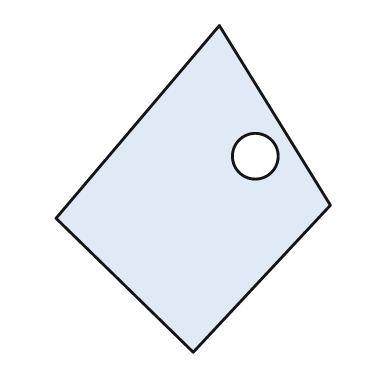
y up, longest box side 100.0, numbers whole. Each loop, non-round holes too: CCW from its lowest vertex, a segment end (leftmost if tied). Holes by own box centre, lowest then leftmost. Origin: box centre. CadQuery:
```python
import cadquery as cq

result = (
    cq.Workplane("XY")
    .moveTo(0.0, -50.0)
    .lineTo(42.0, -5.0)
    .lineTo(8.0, 50.0)
    .lineTo(-42.0, -9.0)
    .close()
    .moveTo(19.0, 10.0)
    .circle(7.0)
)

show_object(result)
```